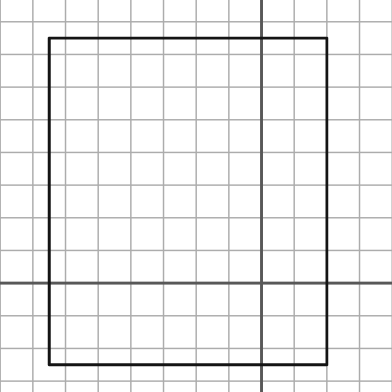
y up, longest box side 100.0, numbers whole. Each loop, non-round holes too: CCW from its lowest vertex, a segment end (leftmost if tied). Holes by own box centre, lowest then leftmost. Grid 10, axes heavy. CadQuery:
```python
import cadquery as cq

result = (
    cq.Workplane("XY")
    .moveTo(-65.0, -25.0)
    .lineTo(20.0, -25.0)
    .lineTo(20.0, 75.0)
    .lineTo(-65.0, 75.0)
    .close()
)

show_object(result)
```